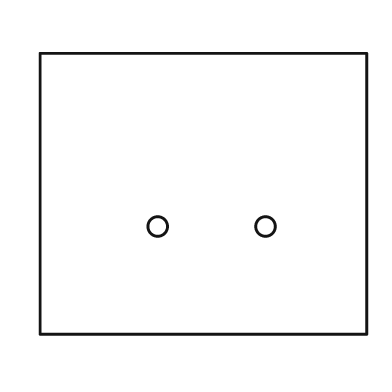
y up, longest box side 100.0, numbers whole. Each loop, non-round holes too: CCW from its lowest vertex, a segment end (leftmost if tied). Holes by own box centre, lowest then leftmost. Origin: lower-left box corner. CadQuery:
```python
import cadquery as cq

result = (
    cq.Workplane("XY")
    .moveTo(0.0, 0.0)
    .lineTo(100.0, 0.0)
    .lineTo(100.0, 86.0)
    .lineTo(0.0, 86.0)
    .close()
    .moveTo(36.0, 33.0)
    .circle(3.0)
    .moveTo(69.0, 33.0)
    .circle(3.0)
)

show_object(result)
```